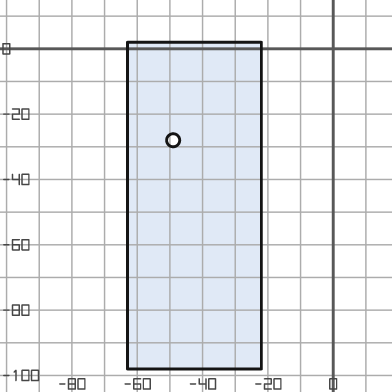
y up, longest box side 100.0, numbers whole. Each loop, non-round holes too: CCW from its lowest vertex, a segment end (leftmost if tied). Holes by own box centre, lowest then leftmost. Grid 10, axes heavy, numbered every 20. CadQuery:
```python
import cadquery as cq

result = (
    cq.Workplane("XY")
    .moveTo(-63.0, -98.0)
    .lineTo(-22.0, -98.0)
    .lineTo(-22.0, 2.0)
    .lineTo(-63.0, 2.0)
    .close()
    .moveTo(-49.0, -28.0)
    .circle(2.0)
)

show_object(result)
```